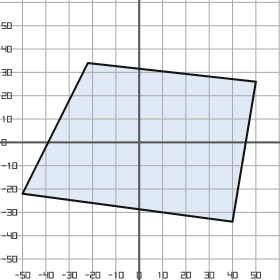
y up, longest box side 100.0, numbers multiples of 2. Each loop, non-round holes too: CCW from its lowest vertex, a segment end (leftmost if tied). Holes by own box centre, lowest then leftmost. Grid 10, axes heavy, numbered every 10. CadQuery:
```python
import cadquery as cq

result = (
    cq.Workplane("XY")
    .moveTo(40.0, -34.0)
    .lineTo(50.0, 26.0)
    .lineTo(-22.0, 34.0)
    .lineTo(-50.0, -22.0)
    .close()
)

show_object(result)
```